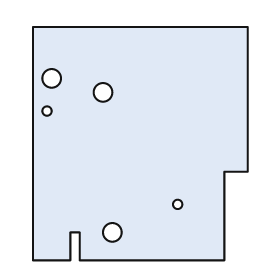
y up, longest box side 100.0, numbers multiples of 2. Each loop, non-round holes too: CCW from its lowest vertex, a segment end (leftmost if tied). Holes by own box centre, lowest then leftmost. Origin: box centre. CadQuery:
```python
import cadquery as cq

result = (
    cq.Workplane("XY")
    .moveTo(-46.0, -50.0)
    .lineTo(-30.0, -50.0)
    .lineTo(-30.0, -38.0)
    .lineTo(-26.0, -38.0)
    .lineTo(-26.0, -50.0)
    .lineTo(36.0, -50.0)
    .lineTo(36.0, -12.0)
    .lineTo(46.0, -12.0)
    .lineTo(46.0, 50.0)
    .lineTo(-46.0, 50.0)
    .close()
    .moveTo(-12.0, -38.0)
    .circle(4.0)
    .moveTo(16.0, -26.0)
    .circle(2.0)
    .moveTo(-40.0, 14.0)
    .circle(2.0)
    .moveTo(-16.0, 22.0)
    .circle(4.0)
    .moveTo(-38.0, 28.0)
    .circle(4.0)
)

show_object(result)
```